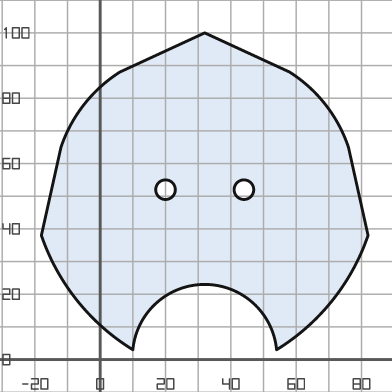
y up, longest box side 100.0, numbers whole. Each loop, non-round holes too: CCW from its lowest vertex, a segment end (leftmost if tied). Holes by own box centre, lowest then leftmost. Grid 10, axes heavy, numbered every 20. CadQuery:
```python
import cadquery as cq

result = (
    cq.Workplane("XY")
    .moveTo(10.0, 3.0)
    .threePointArc((32.0, 23.0), (54.0, 3.0))
    .threePointArc((71.0, 18.0), (82.0, 38.0))
    .lineTo(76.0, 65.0)
    .threePointArc((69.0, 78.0), (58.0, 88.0))
    .lineTo(32.0, 100.0)
    .lineTo(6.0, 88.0)
    .threePointArc((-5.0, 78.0), (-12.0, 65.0))
    .lineTo(-18.0, 38.0)
    .threePointArc((-7.0, 18.0), (10.0, 3.0))
    .close()
    .moveTo(20.0, 52.0)
    .circle(3.0)
    .moveTo(44.0, 52.0)
    .circle(3.0)
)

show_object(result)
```